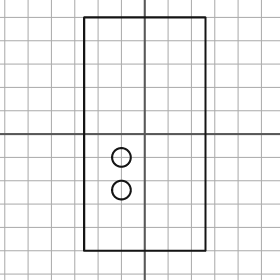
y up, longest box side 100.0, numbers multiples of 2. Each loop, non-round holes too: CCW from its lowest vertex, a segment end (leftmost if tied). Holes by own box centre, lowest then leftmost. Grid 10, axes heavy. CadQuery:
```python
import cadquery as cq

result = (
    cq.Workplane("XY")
    .moveTo(-26.0, -50.0)
    .lineTo(26.0, -50.0)
    .lineTo(26.0, 50.0)
    .lineTo(-26.0, 50.0)
    .close()
    .moveTo(-10.0, -24.0)
    .circle(4.0)
    .moveTo(-10.0, -10.0)
    .circle(4.0)
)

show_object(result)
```